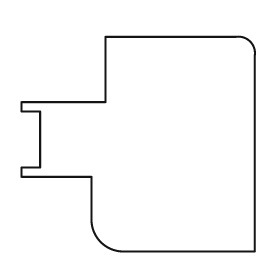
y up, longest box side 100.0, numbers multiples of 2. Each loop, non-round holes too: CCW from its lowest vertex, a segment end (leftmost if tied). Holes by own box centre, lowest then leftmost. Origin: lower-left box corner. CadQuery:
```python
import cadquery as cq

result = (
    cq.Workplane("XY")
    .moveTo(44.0, 0.0)
    .lineTo(100.0, 0.0)
    .lineTo(100.0, 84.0)
    .threePointArc((98.0, 90.0), (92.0, 92.0))
    .lineTo(36.0, 92.0)
    .lineTo(36.0, 64.0)
    .lineTo(0.0, 64.0)
    .lineTo(0.0, 60.0)
    .lineTo(8.0, 60.0)
    .lineTo(8.0, 36.0)
    .lineTo(0.0, 36.0)
    .lineTo(0.0, 32.0)
    .lineTo(30.0, 32.0)
    .lineTo(30.0, 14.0)
    .threePointArc((34.0, 4.0), (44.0, 0.0))
    .close()
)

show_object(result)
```